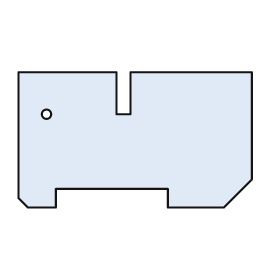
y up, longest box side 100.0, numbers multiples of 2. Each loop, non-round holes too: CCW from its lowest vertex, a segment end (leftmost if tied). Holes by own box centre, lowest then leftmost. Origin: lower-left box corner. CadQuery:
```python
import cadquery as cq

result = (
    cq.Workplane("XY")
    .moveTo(4.0, 0.0)
    .lineTo(16.0, 0.0)
    .lineTo(16.0, 8.0)
    .lineTo(64.0, 8.0)
    .lineTo(64.0, 0.0)
    .lineTo(88.0, 0.0)
    .lineTo(100.0, 12.0)
    .lineTo(100.0, 58.0)
    .lineTo(48.0, 58.0)
    .lineTo(48.0, 40.0)
    .lineTo(42.0, 40.0)
    .lineTo(42.0, 58.0)
    .lineTo(0.0, 58.0)
    .lineTo(0.0, 4.0)
    .close()
    .moveTo(12.0, 40.0)
    .circle(2.0)
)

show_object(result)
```